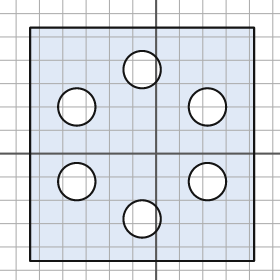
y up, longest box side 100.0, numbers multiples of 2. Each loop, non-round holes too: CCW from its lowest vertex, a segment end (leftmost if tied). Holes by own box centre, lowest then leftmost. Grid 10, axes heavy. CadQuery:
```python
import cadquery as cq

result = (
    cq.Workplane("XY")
    .moveTo(-54.0, -46.0)
    .lineTo(42.0, -46.0)
    .lineTo(42.0, 54.0)
    .lineTo(-54.0, 54.0)
    .close()
    .moveTo(-6.0, -28.0)
    .circle(8.0)
    .moveTo(-34.0, -12.0)
    .circle(8.0)
    .moveTo(22.0, -12.0)
    .circle(8.0)
    .moveTo(-34.0, 20.0)
    .circle(8.0)
    .moveTo(22.0, 20.0)
    .circle(8.0)
    .moveTo(-6.0, 36.0)
    .circle(8.0)
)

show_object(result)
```